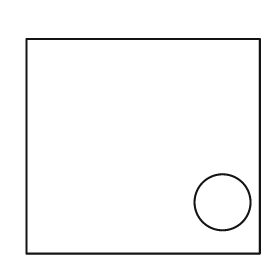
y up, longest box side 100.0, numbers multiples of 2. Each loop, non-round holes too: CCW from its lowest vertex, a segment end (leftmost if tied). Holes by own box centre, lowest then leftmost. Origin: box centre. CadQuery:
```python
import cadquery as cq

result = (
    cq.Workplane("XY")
    .moveTo(-50.0, -46.0)
    .lineTo(50.0, -46.0)
    .lineTo(50.0, 46.0)
    .lineTo(-50.0, 46.0)
    .close()
    .moveTo(34.0, -24.0)
    .circle(12.0)
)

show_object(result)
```